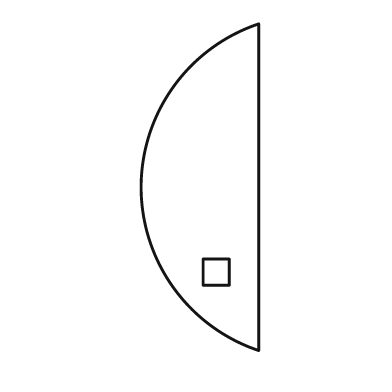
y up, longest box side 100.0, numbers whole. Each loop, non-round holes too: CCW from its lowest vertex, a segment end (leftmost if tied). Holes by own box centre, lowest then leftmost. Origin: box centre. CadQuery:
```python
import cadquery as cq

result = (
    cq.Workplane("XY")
    .moveTo(18.0, -50.0)
    .lineTo(18.0, 50.0)
    .threePointArc((-18.0, 0.0), (18.0, -50.0))
    .close()
    .moveTo(1.0, -30.0)
    .lineTo(9.0, -30.0)
    .lineTo(9.0, -22.0)
    .lineTo(1.0, -22.0)
    .close()
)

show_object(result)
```